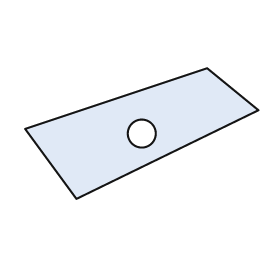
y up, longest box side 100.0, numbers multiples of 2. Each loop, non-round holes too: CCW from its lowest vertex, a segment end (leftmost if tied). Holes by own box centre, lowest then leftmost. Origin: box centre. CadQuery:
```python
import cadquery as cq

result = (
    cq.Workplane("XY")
    .moveTo(-28.0, -28.0)
    .lineTo(50.0, 10.0)
    .lineTo(28.0, 28.0)
    .lineTo(-50.0, 2.0)
    .close()
    .moveTo(0.0, 0.0)
    .circle(6.0)
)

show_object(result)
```